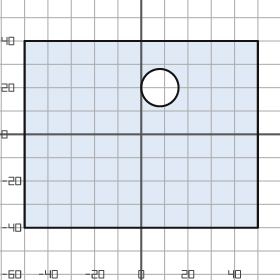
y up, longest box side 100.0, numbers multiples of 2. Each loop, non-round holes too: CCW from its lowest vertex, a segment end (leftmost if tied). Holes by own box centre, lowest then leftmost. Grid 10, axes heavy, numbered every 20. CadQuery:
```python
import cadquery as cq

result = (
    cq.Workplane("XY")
    .moveTo(-50.0, -40.0)
    .lineTo(50.0, -40.0)
    .lineTo(50.0, 40.0)
    .lineTo(-50.0, 40.0)
    .close()
    .moveTo(8.0, 20.0)
    .circle(8.0)
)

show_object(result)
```